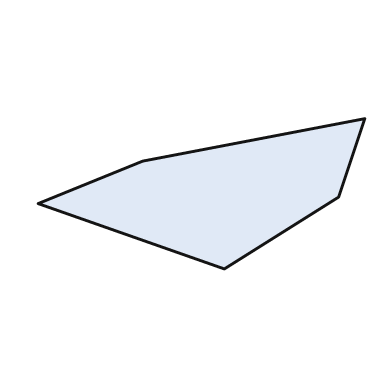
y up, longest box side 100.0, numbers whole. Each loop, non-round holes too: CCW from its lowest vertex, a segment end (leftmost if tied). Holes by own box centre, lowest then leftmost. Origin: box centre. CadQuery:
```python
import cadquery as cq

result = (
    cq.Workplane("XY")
    .moveTo(7.0, -23.0)
    .lineTo(42.0, -1.0)
    .lineTo(50.0, 23.0)
    .lineTo(-18.0, 10.0)
    .lineTo(-50.0, -3.0)
    .close()
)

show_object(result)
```